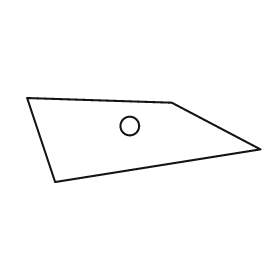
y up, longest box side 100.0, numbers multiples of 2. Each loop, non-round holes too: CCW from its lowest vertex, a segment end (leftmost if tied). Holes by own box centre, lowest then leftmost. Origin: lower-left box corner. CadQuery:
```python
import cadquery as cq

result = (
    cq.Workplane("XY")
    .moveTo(12.0, 0.0)
    .lineTo(100.0, 14.0)
    .lineTo(62.0, 34.0)
    .lineTo(0.0, 36.0)
    .close()
    .moveTo(44.0, 24.0)
    .circle(4.0)
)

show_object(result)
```